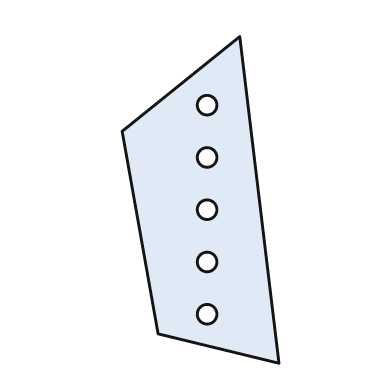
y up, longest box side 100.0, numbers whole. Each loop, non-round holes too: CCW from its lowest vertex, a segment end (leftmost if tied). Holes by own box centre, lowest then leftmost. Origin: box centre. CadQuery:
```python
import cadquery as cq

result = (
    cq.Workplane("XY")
    .moveTo(24.0, -50.0)
    .lineTo(12.0, 50.0)
    .lineTo(-24.0, 21.0)
    .lineTo(-13.0, -41.0)
    .close()
    .moveTo(2.0, -35.0)
    .circle(3.0)
    .moveTo(2.0, -19.0)
    .circle(3.0)
    .moveTo(2.0, -3.0)
    .circle(3.0)
    .moveTo(2.0, 13.0)
    .circle(3.0)
    .moveTo(2.0, 29.0)
    .circle(3.0)
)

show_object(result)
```